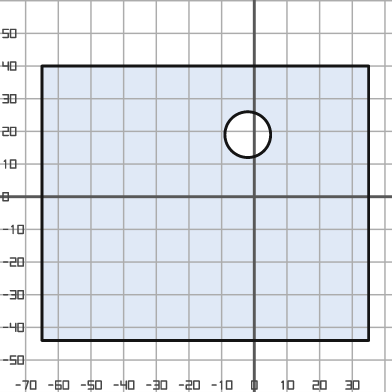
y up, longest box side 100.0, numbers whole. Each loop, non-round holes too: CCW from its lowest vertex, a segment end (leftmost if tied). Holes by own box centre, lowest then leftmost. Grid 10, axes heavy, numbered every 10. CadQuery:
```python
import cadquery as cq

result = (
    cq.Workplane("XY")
    .moveTo(-65.0, -44.0)
    .lineTo(35.0, -44.0)
    .lineTo(35.0, 40.0)
    .lineTo(-65.0, 40.0)
    .close()
    .moveTo(-2.0, 19.0)
    .circle(7.0)
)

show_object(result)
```